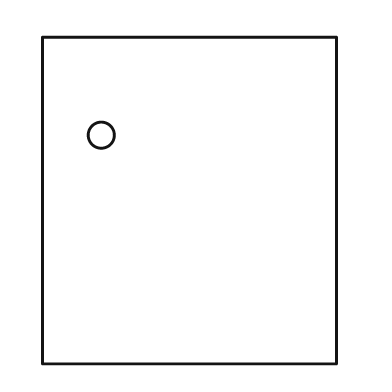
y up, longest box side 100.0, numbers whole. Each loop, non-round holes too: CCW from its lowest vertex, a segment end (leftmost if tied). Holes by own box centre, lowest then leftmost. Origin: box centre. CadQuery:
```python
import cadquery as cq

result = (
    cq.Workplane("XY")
    .moveTo(-45.0, -50.0)
    .lineTo(45.0, -50.0)
    .lineTo(45.0, 50.0)
    .lineTo(-45.0, 50.0)
    .close()
    .moveTo(-27.0, 20.0)
    .circle(4.0)
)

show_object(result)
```